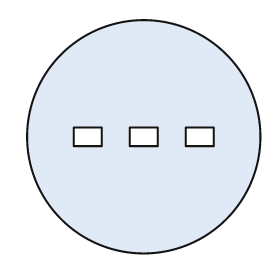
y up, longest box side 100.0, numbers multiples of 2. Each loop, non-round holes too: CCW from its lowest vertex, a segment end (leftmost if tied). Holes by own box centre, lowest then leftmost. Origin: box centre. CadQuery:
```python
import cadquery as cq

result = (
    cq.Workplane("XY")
    .moveTo(0.0, 0.0)
    .circle(50.0)
    .moveTo(-30.0, -4.0)
    .lineTo(-18.0, -4.0)
    .lineTo(-18.0, 4.0)
    .lineTo(-30.0, 4.0)
    .close()
    .moveTo(-6.0, -4.0)
    .lineTo(6.0, -4.0)
    .lineTo(6.0, 4.0)
    .lineTo(-6.0, 4.0)
    .close()
    .moveTo(18.0, -4.0)
    .lineTo(30.0, -4.0)
    .lineTo(30.0, 4.0)
    .lineTo(18.0, 4.0)
    .close()
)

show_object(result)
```